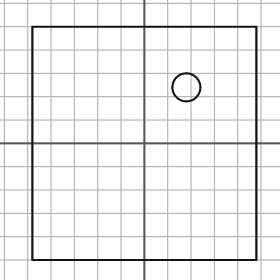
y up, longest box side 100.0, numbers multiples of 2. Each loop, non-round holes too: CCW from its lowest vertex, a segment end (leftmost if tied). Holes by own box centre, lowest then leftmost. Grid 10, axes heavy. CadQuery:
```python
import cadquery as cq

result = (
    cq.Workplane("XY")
    .moveTo(-48.0, -50.0)
    .lineTo(48.0, -50.0)
    .lineTo(48.0, 50.0)
    .lineTo(-48.0, 50.0)
    .close()
    .moveTo(18.0, 24.0)
    .circle(6.0)
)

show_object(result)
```